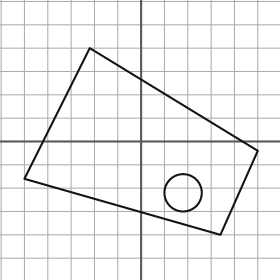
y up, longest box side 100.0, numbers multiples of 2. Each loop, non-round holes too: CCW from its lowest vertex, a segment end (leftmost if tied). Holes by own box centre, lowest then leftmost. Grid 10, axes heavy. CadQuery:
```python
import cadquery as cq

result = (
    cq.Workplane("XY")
    .moveTo(34.0, -40.0)
    .lineTo(50.0, -4.0)
    .lineTo(-22.0, 40.0)
    .lineTo(-50.0, -16.0)
    .close()
    .moveTo(18.0, -22.0)
    .circle(8.0)
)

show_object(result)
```